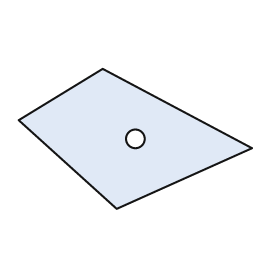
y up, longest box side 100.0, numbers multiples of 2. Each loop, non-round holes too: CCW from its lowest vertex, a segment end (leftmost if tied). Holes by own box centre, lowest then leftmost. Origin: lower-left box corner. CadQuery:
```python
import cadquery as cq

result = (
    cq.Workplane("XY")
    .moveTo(42.0, 0.0)
    .lineTo(100.0, 26.0)
    .lineTo(36.0, 60.0)
    .lineTo(0.0, 38.0)
    .close()
    .moveTo(50.0, 30.0)
    .circle(4.0)
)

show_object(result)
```